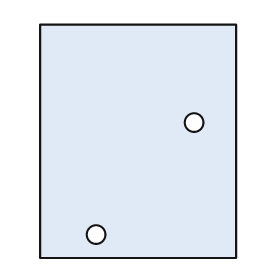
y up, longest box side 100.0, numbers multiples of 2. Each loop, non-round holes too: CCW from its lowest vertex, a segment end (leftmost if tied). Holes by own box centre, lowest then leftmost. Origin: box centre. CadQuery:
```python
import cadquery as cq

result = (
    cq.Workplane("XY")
    .moveTo(-42.0, -50.0)
    .lineTo(42.0, -50.0)
    .lineTo(42.0, 50.0)
    .lineTo(-42.0, 50.0)
    .close()
    .moveTo(-18.0, -40.0)
    .circle(4.0)
    .moveTo(24.0, 8.0)
    .circle(4.0)
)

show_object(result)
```